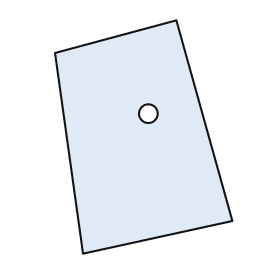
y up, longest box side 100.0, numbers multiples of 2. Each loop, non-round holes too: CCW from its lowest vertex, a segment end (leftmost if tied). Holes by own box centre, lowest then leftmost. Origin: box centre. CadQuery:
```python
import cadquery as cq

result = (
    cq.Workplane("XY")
    .moveTo(-26.0, -50.0)
    .lineTo(38.0, -36.0)
    .lineTo(14.0, 50.0)
    .lineTo(-38.0, 36.0)
    .close()
    .moveTo(2.0, 10.0)
    .circle(4.0)
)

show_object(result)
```